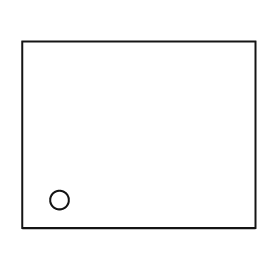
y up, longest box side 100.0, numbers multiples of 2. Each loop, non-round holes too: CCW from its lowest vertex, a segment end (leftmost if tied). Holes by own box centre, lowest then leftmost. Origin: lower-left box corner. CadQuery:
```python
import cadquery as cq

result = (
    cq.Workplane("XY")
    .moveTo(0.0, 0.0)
    .lineTo(100.0, 0.0)
    .lineTo(100.0, 80.0)
    .lineTo(0.0, 80.0)
    .close()
    .moveTo(16.0, 12.0)
    .circle(4.0)
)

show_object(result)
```